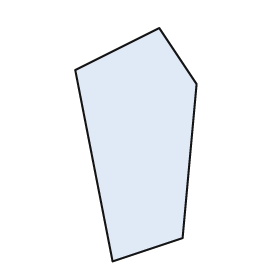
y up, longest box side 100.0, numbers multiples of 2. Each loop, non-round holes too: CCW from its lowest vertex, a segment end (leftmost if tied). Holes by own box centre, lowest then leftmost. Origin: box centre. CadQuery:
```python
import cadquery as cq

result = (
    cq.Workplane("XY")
    .moveTo(-10.0, -50.0)
    .lineTo(20.0, -40.0)
    .lineTo(26.0, 26.0)
    .lineTo(10.0, 50.0)
    .lineTo(-26.0, 32.0)
    .close()
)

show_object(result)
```